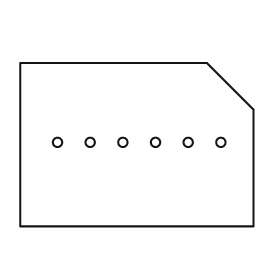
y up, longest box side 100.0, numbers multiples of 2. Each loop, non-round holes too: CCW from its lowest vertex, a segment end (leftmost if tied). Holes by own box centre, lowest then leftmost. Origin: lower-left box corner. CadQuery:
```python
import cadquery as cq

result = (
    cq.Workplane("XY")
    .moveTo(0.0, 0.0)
    .lineTo(100.0, 0.0)
    .lineTo(100.0, 50.0)
    .lineTo(80.0, 70.0)
    .lineTo(0.0, 70.0)
    .close()
    .moveTo(16.0, 36.0)
    .circle(2.0)
    .moveTo(30.0, 36.0)
    .circle(2.0)
    .moveTo(44.0, 36.0)
    .circle(2.0)
    .moveTo(58.0, 36.0)
    .circle(2.0)
    .moveTo(72.0, 36.0)
    .circle(2.0)
    .moveTo(86.0, 36.0)
    .circle(2.0)
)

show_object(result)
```